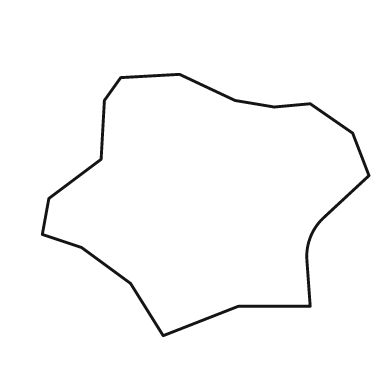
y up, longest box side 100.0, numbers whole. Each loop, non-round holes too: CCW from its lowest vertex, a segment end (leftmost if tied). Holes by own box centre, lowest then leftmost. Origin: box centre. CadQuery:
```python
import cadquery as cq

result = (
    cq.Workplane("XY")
    .moveTo(-13.0, -40.0)
    .lineTo(10.0, -31.0)
    .lineTo(32.0, -31.0)
    .lineTo(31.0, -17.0)
    .threePointArc((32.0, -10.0), (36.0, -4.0))
    .lineTo(50.0, 9.0)
    .lineTo(45.0, 22.0)
    .lineTo(32.0, 31.0)
    .lineTo(21.0, 30.0)
    .lineTo(9.0, 32.0)
    .lineTo(-8.0, 40.0)
    .lineTo(-26.0, 39.0)
    .lineTo(-31.0, 32.0)
    .lineTo(-32.0, 14.0)
    .lineTo(-48.0, 2.0)
    .lineTo(-50.0, -9.0)
    .lineTo(-38.0, -13.0)
    .lineTo(-23.0, -24.0)
    .close()
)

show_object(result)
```